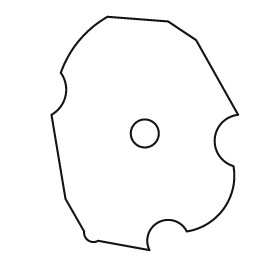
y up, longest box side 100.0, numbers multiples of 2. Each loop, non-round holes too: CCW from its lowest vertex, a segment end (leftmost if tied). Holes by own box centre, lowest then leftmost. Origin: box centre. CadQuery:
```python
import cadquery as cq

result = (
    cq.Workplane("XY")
    .moveTo(2.0, -50.0)
    .threePointArc((6.0, -38.0), (18.0, -42.0))
    .threePointArc((34.0, -32.0), (38.0, -14.0))
    .threePointArc((30.0, -2.0), (40.0, 8.0))
    .lineTo(22.0, 40.0)
    .lineTo(10.0, 48.0)
    .lineTo(-16.0, 50.0)
    .threePointArc((-28.0, 40.0), (-36.0, 26.0))
    .threePointArc((-34.0, 16.0), (-40.0, 8.0))
    .lineTo(-34.0, -28.0)
    .lineTo(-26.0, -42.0)
    .threePointArc((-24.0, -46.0), (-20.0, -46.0))
    .close()
    .moveTo(0.0, 0.0)
    .circle(6.0)
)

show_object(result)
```